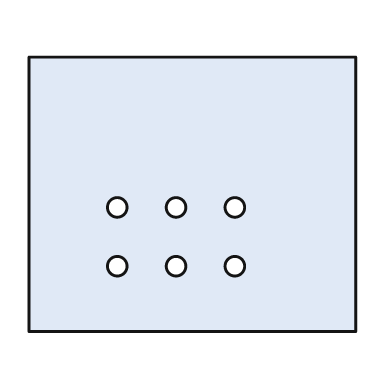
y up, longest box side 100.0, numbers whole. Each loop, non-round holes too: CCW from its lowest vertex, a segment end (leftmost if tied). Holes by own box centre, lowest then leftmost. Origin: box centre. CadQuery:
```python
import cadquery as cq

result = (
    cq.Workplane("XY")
    .moveTo(-50.0, -42.0)
    .lineTo(50.0, -42.0)
    .lineTo(50.0, 42.0)
    .lineTo(-50.0, 42.0)
    .close()
    .moveTo(-23.0, -22.0)
    .circle(3.0)
    .moveTo(-5.0, -22.0)
    .circle(3.0)
    .moveTo(13.0, -22.0)
    .circle(3.0)
    .moveTo(-23.0, -4.0)
    .circle(3.0)
    .moveTo(-5.0, -4.0)
    .circle(3.0)
    .moveTo(13.0, -4.0)
    .circle(3.0)
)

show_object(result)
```